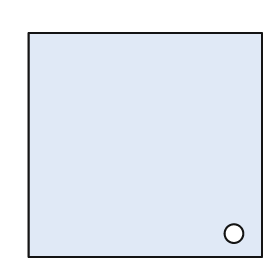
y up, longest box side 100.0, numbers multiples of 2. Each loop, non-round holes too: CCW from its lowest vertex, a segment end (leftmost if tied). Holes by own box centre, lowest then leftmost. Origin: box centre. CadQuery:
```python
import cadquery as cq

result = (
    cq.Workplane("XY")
    .moveTo(-50.0, -48.0)
    .lineTo(50.0, -48.0)
    .lineTo(50.0, 48.0)
    .lineTo(-50.0, 48.0)
    .close()
    .moveTo(38.0, -38.0)
    .circle(4.0)
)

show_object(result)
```